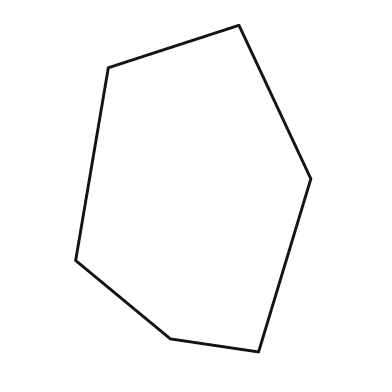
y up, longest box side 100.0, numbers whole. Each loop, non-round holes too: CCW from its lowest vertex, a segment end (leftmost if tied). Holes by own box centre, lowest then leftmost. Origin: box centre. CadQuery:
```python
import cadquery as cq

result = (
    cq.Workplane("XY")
    .moveTo(20.0, -50.0)
    .lineTo(36.0, 3.0)
    .lineTo(14.0, 50.0)
    .lineTo(-26.0, 37.0)
    .lineTo(-36.0, -22.0)
    .lineTo(-7.0, -46.0)
    .close()
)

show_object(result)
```